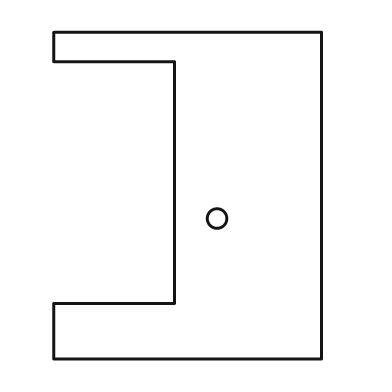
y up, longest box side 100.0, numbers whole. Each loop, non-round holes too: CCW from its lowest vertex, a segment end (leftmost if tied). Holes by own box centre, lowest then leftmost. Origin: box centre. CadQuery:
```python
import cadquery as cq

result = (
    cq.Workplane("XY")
    .moveTo(-41.0, -50.0)
    .lineTo(41.0, -50.0)
    .lineTo(41.0, 50.0)
    .lineTo(-41.0, 50.0)
    .lineTo(-41.0, 41.0)
    .lineTo(-4.0, 41.0)
    .lineTo(-4.0, -33.0)
    .lineTo(-41.0, -33.0)
    .close()
    .moveTo(9.0, -7.0)
    .circle(3.0)
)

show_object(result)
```